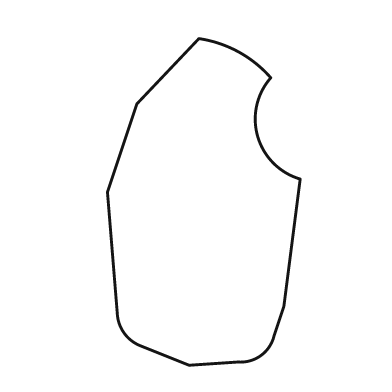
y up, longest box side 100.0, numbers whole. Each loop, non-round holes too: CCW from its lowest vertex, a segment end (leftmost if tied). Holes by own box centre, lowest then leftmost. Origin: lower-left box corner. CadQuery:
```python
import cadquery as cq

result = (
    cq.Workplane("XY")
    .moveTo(25.0, 0.0)
    .lineTo(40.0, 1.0)
    .threePointArc((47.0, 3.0), (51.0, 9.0))
    .lineTo(54.0, 18.0)
    .lineTo(59.0, 57.0)
    .threePointArc((46.0, 70.0), (50.0, 88.0))
    .threePointArc((40.0, 96.0), (28.0, 100.0))
    .lineTo(9.0, 80.0)
    .lineTo(0.0, 53.0)
    .lineTo(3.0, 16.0)
    .threePointArc((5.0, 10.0), (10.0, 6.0))
    .close()
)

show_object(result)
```